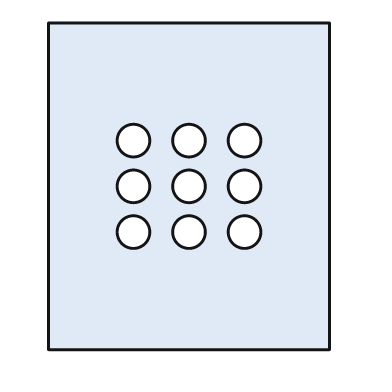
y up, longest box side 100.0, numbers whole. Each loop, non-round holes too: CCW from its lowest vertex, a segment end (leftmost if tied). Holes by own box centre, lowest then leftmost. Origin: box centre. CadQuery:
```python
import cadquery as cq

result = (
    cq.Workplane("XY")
    .moveTo(-43.0, -50.0)
    .lineTo(43.0, -50.0)
    .lineTo(43.0, 50.0)
    .lineTo(-43.0, 50.0)
    .close()
    .moveTo(-17.0, -14.0)
    .circle(5.0)
    .moveTo(0.0, -14.0)
    .circle(5.0)
    .moveTo(17.0, -14.0)
    .circle(5.0)
    .moveTo(-17.0, 0.0)
    .circle(5.0)
    .moveTo(0.0, 0.0)
    .circle(5.0)
    .moveTo(17.0, 0.0)
    .circle(5.0)
    .moveTo(-17.0, 14.0)
    .circle(5.0)
    .moveTo(0.0, 14.0)
    .circle(5.0)
    .moveTo(17.0, 14.0)
    .circle(5.0)
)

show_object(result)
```